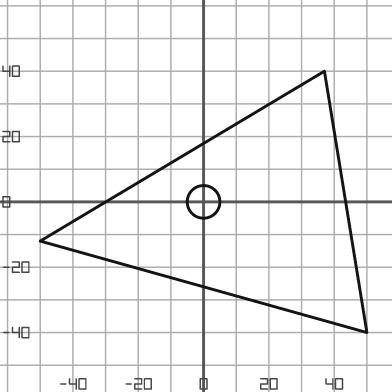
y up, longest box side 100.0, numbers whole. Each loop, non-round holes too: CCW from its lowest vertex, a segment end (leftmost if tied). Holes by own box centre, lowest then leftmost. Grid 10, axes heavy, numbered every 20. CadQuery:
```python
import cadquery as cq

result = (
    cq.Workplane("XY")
    .moveTo(50.0, -40.0)
    .lineTo(37.0, 40.0)
    .lineTo(-50.0, -12.0)
    .close()
    .moveTo(0.0, 0.0)
    .circle(5.0)
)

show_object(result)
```